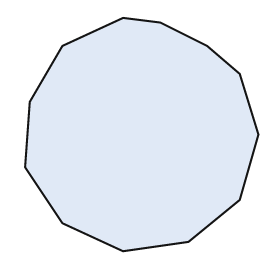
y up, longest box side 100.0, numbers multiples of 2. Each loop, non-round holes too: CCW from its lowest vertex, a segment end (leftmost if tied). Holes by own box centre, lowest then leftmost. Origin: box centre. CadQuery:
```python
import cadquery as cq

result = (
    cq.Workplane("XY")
    .moveTo(-8.0, -50.0)
    .lineTo(20.0, -46.0)
    .lineTo(42.0, -28.0)
    .lineTo(50.0, 0.0)
    .lineTo(42.0, 26.0)
    .lineTo(28.0, 38.0)
    .lineTo(8.0, 48.0)
    .lineTo(-8.0, 50.0)
    .lineTo(-34.0, 38.0)
    .lineTo(-48.0, 14.0)
    .lineTo(-50.0, -14.0)
    .lineTo(-34.0, -38.0)
    .close()
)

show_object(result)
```